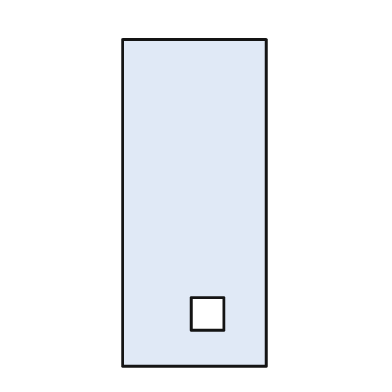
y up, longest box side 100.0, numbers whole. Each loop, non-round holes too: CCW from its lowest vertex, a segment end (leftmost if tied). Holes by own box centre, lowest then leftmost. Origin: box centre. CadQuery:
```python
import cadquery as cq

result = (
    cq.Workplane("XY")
    .moveTo(-22.0, -50.0)
    .lineTo(22.0, -50.0)
    .lineTo(22.0, 50.0)
    .lineTo(-22.0, 50.0)
    .close()
    .moveTo(-1.0, -39.0)
    .lineTo(9.0, -39.0)
    .lineTo(9.0, -29.0)
    .lineTo(-1.0, -29.0)
    .close()
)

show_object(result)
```